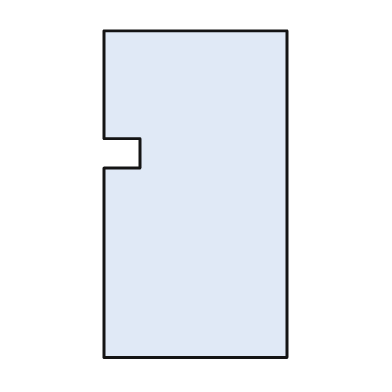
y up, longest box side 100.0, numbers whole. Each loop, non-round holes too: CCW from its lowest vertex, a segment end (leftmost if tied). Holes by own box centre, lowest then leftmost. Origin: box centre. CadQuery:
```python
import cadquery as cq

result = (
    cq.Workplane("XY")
    .moveTo(-28.0, -50.0)
    .lineTo(28.0, -50.0)
    .lineTo(28.0, 50.0)
    .lineTo(-28.0, 50.0)
    .lineTo(-28.0, 17.0)
    .lineTo(-17.0, 17.0)
    .lineTo(-17.0, 8.0)
    .lineTo(-28.0, 8.0)
    .close()
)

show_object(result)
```